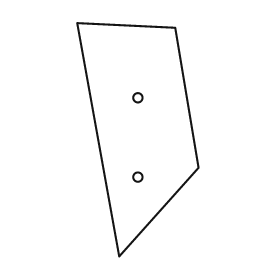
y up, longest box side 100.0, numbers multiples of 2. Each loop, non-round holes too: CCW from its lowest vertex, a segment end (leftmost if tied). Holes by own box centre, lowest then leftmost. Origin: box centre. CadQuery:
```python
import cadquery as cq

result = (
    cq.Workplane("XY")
    .moveTo(-8.0, -50.0)
    .lineTo(26.0, -12.0)
    .lineTo(16.0, 48.0)
    .lineTo(-26.0, 50.0)
    .close()
    .moveTo(0.0, -16.0)
    .circle(2.0)
    .moveTo(0.0, 18.0)
    .circle(2.0)
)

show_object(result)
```